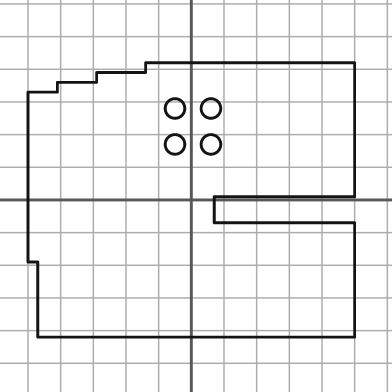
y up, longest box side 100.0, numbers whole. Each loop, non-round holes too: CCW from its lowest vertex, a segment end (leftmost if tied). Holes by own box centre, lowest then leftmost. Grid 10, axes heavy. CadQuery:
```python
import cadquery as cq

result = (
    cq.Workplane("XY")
    .moveTo(-47.0, -42.0)
    .lineTo(50.0, -42.0)
    .lineTo(50.0, -7.0)
    .lineTo(7.0, -7.0)
    .lineTo(7.0, 1.0)
    .lineTo(50.0, 1.0)
    .lineTo(50.0, 42.0)
    .lineTo(-14.0, 42.0)
    .lineTo(-14.0, 39.0)
    .lineTo(-29.0, 39.0)
    .lineTo(-29.0, 36.0)
    .lineTo(-41.0, 36.0)
    .lineTo(-41.0, 33.0)
    .lineTo(-50.0, 33.0)
    .lineTo(-50.0, -19.0)
    .lineTo(-47.0, -19.0)
    .close()
    .moveTo(-5.0, 17.0)
    .circle(3.0)
    .moveTo(6.0, 17.0)
    .circle(3.0)
    .moveTo(-5.0, 28.0)
    .circle(3.0)
    .moveTo(6.0, 28.0)
    .circle(3.0)
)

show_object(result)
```